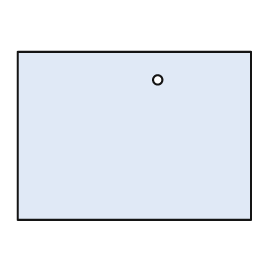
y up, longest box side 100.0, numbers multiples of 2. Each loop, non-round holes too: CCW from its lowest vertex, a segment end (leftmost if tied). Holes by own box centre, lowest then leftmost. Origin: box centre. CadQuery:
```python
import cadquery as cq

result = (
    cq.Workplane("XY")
    .moveTo(-50.0, -36.0)
    .lineTo(50.0, -36.0)
    .lineTo(50.0, 36.0)
    .lineTo(-50.0, 36.0)
    .close()
    .moveTo(10.0, 24.0)
    .circle(2.0)
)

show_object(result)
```